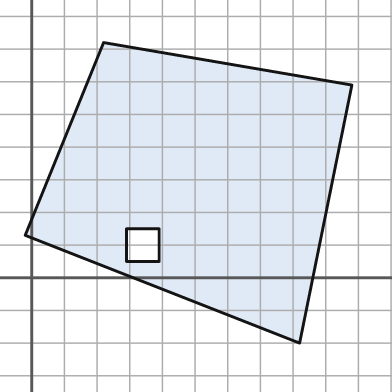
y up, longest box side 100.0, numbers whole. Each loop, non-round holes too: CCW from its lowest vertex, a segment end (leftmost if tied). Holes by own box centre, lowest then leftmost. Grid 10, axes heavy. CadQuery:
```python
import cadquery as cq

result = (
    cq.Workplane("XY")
    .moveTo(82.0, -20.0)
    .lineTo(98.0, 59.0)
    .lineTo(22.0, 72.0)
    .lineTo(-2.0, 13.0)
    .close()
    .moveTo(29.0, 5.0)
    .lineTo(39.0, 5.0)
    .lineTo(39.0, 15.0)
    .lineTo(29.0, 15.0)
    .close()
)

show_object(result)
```